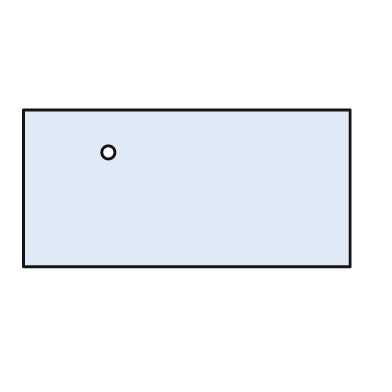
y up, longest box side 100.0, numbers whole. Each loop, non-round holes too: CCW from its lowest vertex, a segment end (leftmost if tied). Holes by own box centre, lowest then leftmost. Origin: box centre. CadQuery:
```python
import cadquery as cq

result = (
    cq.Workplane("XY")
    .moveTo(-50.0, -24.0)
    .lineTo(50.0, -24.0)
    .lineTo(50.0, 24.0)
    .lineTo(-50.0, 24.0)
    .close()
    .moveTo(-24.0, 11.0)
    .circle(2.0)
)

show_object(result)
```